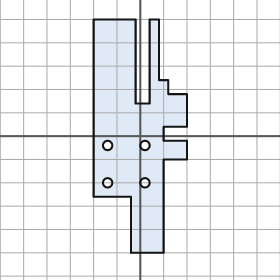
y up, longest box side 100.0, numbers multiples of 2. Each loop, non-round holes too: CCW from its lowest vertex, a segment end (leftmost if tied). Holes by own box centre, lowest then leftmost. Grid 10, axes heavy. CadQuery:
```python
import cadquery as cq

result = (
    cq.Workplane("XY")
    .moveTo(-4.0, -50.0)
    .lineTo(10.0, -50.0)
    .lineTo(10.0, -10.0)
    .lineTo(20.0, -10.0)
    .lineTo(20.0, -2.0)
    .lineTo(10.0, -2.0)
    .lineTo(10.0, 4.0)
    .lineTo(20.0, 4.0)
    .lineTo(20.0, 18.0)
    .lineTo(12.0, 18.0)
    .lineTo(12.0, 24.0)
    .lineTo(8.0, 24.0)
    .lineTo(8.0, 50.0)
    .lineTo(4.0, 50.0)
    .lineTo(4.0, 14.0)
    .lineTo(-2.0, 14.0)
    .lineTo(-2.0, 50.0)
    .lineTo(-20.0, 50.0)
    .lineTo(-20.0, -26.0)
    .lineTo(-4.0, -26.0)
    .close()
    .moveTo(-14.0, -20.0)
    .circle(2.0)
    .moveTo(2.0, -20.0)
    .circle(2.0)
    .moveTo(-14.0, -4.0)
    .circle(2.0)
    .moveTo(2.0, -4.0)
    .circle(2.0)
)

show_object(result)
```